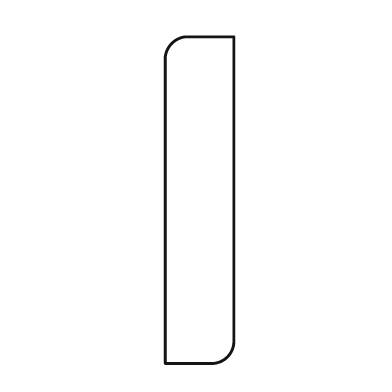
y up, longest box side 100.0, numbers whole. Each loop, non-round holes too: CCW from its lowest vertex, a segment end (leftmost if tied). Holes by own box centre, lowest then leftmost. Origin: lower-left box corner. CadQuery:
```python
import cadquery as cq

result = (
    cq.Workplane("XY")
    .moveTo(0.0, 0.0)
    .lineTo(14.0, 0.0)
    .threePointArc((19.0, 2.0), (21.0, 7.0))
    .lineTo(21.0, 100.0)
    .lineTo(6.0, 100.0)
    .threePointArc((2.0, 98.0), (0.0, 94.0))
    .close()
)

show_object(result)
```